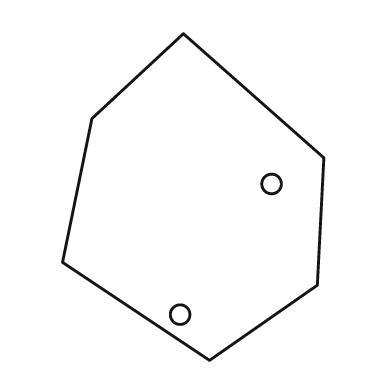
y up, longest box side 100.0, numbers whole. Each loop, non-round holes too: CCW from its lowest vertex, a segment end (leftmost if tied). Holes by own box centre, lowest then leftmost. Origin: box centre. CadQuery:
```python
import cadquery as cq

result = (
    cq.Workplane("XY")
    .moveTo(5.0, -50.0)
    .lineTo(38.0, -27.0)
    .lineTo(40.0, 12.0)
    .lineTo(-3.0, 50.0)
    .lineTo(-31.0, 24.0)
    .lineTo(-40.0, -20.0)
    .close()
    .moveTo(-4.0, -36.0)
    .circle(3.0)
    .moveTo(24.0, 4.0)
    .circle(3.0)
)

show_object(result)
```